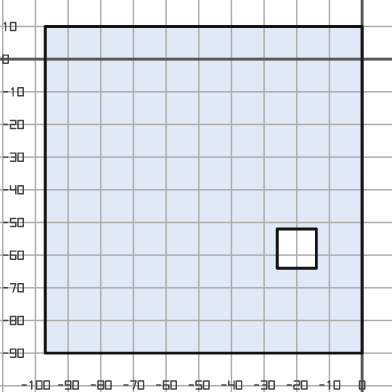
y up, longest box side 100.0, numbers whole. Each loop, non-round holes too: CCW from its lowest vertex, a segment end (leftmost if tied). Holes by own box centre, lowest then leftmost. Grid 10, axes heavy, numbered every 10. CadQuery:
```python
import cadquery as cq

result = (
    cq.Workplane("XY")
    .moveTo(-97.0, -90.0)
    .lineTo(0.0, -90.0)
    .lineTo(0.0, 10.0)
    .lineTo(-97.0, 10.0)
    .close()
    .moveTo(-26.0, -64.0)
    .lineTo(-14.0, -64.0)
    .lineTo(-14.0, -52.0)
    .lineTo(-26.0, -52.0)
    .close()
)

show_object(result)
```